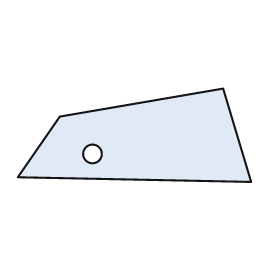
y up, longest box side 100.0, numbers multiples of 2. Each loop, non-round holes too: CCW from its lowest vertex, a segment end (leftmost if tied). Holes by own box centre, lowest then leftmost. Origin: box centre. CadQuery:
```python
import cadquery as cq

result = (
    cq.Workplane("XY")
    .moveTo(50.0, -20.0)
    .lineTo(38.0, 20.0)
    .lineTo(-32.0, 8.0)
    .lineTo(-50.0, -18.0)
    .close()
    .moveTo(-18.0, -8.0)
    .circle(4.0)
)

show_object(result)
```